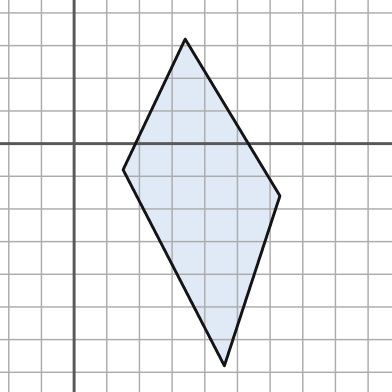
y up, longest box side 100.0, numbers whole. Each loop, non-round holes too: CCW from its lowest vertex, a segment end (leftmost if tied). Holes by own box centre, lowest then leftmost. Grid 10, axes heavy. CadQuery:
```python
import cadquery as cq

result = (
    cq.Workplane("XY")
    .moveTo(46.0, -68.0)
    .lineTo(63.0, -16.0)
    .lineTo(34.0, 32.0)
    .lineTo(15.0, -8.0)
    .close()
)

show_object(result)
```